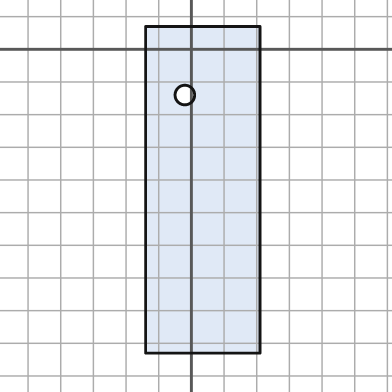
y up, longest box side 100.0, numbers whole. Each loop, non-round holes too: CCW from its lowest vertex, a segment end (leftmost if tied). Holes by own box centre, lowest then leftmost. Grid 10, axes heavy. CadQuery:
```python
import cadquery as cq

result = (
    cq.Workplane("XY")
    .moveTo(-14.0, -93.0)
    .lineTo(21.0, -93.0)
    .lineTo(21.0, 7.0)
    .lineTo(-14.0, 7.0)
    .close()
    .moveTo(-2.0, -14.0)
    .circle(3.0)
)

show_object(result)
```